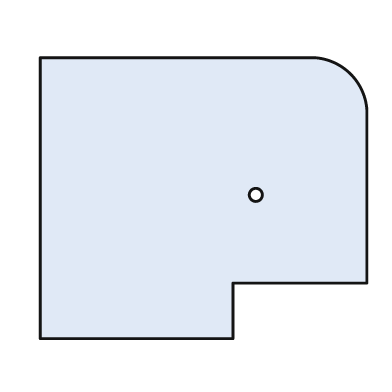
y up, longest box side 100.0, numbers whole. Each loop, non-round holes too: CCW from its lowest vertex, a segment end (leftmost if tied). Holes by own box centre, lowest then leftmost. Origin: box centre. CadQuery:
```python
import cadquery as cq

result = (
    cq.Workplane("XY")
    .moveTo(-50.0, -43.0)
    .lineTo(9.0, -43.0)
    .lineTo(9.0, -26.0)
    .lineTo(50.0, -26.0)
    .lineTo(50.0, 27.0)
    .threePointArc((45.0, 38.0), (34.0, 43.0))
    .lineTo(-50.0, 43.0)
    .close()
    .moveTo(16.0, 1.0)
    .circle(2.0)
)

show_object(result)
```